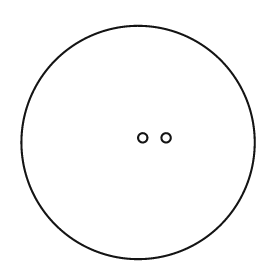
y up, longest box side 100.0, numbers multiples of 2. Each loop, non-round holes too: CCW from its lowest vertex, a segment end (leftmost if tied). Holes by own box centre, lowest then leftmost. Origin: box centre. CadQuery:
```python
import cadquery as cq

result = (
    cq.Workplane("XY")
    .moveTo(0.0, 0.0)
    .circle(50.0)
    .moveTo(2.0, 2.0)
    .circle(2.0)
    .moveTo(12.0, 2.0)
    .circle(2.0)
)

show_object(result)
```